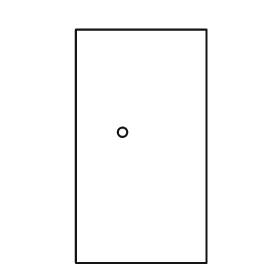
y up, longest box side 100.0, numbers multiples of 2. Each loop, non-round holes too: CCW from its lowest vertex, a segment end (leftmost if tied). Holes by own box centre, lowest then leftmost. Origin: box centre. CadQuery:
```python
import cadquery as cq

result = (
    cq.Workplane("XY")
    .moveTo(-28.0, -50.0)
    .lineTo(28.0, -50.0)
    .lineTo(28.0, 50.0)
    .lineTo(-28.0, 50.0)
    .close()
    .moveTo(-8.0, 6.0)
    .circle(2.0)
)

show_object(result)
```